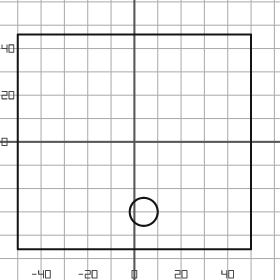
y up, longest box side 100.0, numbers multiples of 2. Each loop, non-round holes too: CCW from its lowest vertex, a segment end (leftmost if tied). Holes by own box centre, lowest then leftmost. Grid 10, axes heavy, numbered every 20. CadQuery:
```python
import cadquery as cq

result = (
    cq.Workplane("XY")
    .moveTo(-50.0, -46.0)
    .lineTo(50.0, -46.0)
    .lineTo(50.0, 46.0)
    .lineTo(-50.0, 46.0)
    .close()
    .moveTo(4.0, -30.0)
    .circle(6.0)
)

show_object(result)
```